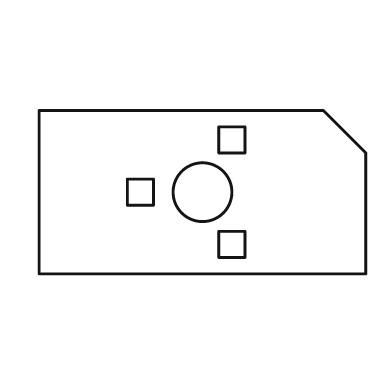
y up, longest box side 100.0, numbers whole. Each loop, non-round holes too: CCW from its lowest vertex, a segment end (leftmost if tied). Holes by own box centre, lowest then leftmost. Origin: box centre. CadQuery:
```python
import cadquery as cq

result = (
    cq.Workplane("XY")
    .moveTo(-50.0, -25.0)
    .lineTo(50.0, -25.0)
    .lineTo(50.0, 12.0)
    .lineTo(37.0, 25.0)
    .lineTo(-50.0, 25.0)
    .close()
    .moveTo(5.0, -20.0)
    .lineTo(13.0, -20.0)
    .lineTo(13.0, -12.0)
    .lineTo(5.0, -12.0)
    .close()
    .moveTo(-23.0, -4.0)
    .lineTo(-15.0, -4.0)
    .lineTo(-15.0, 4.0)
    .lineTo(-23.0, 4.0)
    .close()
    .moveTo(0.0, 0.0)
    .circle(9.0)
    .moveTo(5.0, 12.0)
    .lineTo(13.0, 12.0)
    .lineTo(13.0, 20.0)
    .lineTo(5.0, 20.0)
    .close()
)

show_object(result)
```